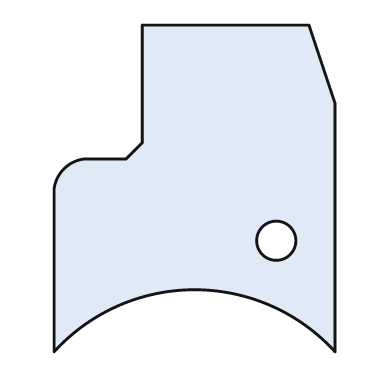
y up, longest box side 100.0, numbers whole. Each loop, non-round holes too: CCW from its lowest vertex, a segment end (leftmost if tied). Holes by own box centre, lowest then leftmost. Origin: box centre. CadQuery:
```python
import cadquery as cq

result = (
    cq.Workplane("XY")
    .moveTo(-43.0, -50.0)
    .threePointArc((0.0, -31.0), (43.0, -50.0))
    .lineTo(43.0, 26.0)
    .lineTo(35.0, 50.0)
    .lineTo(-16.0, 50.0)
    .lineTo(-16.0, 14.0)
    .lineTo(-21.0, 9.0)
    .lineTo(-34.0, 9.0)
    .threePointArc((-40.0, 6.0), (-43.0, 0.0))
    .close()
    .moveTo(25.0, -16.0)
    .circle(6.0)
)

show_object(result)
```